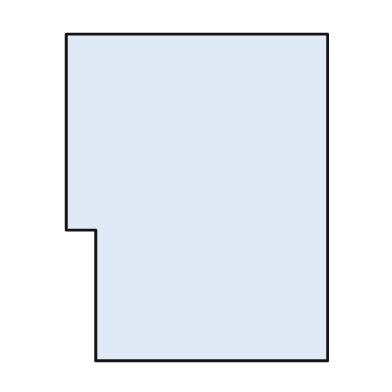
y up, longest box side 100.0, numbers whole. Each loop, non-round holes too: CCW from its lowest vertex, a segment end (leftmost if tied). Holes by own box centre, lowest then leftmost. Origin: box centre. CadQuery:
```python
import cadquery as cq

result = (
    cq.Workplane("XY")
    .moveTo(-31.0, -50.0)
    .lineTo(40.0, -50.0)
    .lineTo(40.0, 50.0)
    .lineTo(-40.0, 50.0)
    .lineTo(-40.0, -10.0)
    .lineTo(-31.0, -10.0)
    .close()
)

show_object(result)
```